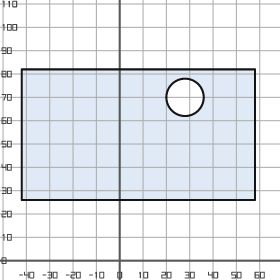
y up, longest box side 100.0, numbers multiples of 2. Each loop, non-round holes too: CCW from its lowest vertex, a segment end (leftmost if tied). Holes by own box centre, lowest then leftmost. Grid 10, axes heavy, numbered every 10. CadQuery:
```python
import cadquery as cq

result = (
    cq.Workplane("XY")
    .moveTo(-42.0, 26.0)
    .lineTo(58.0, 26.0)
    .lineTo(58.0, 82.0)
    .lineTo(-42.0, 82.0)
    .close()
    .moveTo(28.0, 70.0)
    .circle(8.0)
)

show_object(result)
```